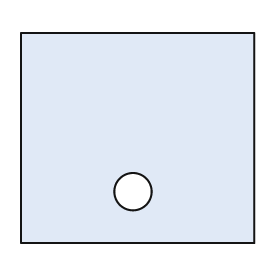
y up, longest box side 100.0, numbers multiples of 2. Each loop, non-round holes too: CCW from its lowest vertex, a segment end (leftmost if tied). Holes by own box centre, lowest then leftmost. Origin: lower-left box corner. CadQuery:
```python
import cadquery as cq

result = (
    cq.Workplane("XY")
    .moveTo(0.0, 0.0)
    .lineTo(100.0, 0.0)
    .lineTo(100.0, 90.0)
    .lineTo(0.0, 90.0)
    .close()
    .moveTo(48.0, 22.0)
    .circle(8.0)
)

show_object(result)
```